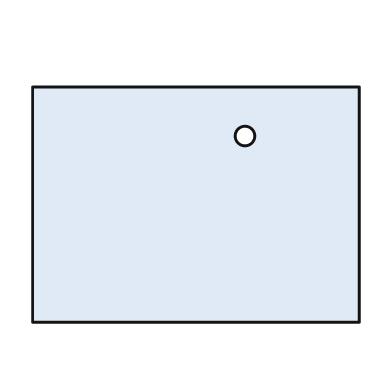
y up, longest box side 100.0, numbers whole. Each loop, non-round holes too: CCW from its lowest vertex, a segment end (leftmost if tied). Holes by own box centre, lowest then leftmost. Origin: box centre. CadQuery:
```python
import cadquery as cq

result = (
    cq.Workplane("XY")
    .moveTo(-50.0, -36.0)
    .lineTo(50.0, -36.0)
    .lineTo(50.0, 36.0)
    .lineTo(-50.0, 36.0)
    .close()
    .moveTo(15.0, 21.0)
    .circle(3.0)
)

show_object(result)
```